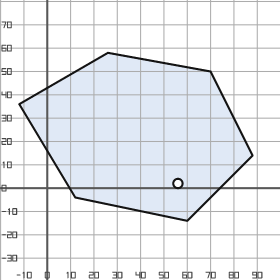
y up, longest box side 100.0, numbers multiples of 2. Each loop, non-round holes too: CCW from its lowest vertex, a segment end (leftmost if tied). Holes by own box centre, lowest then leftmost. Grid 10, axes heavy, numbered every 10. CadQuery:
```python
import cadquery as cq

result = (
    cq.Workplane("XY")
    .moveTo(60.0, -14.0)
    .lineTo(88.0, 14.0)
    .lineTo(70.0, 50.0)
    .lineTo(26.0, 58.0)
    .lineTo(-12.0, 36.0)
    .lineTo(12.0, -4.0)
    .close()
    .moveTo(56.0, 2.0)
    .circle(2.0)
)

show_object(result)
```